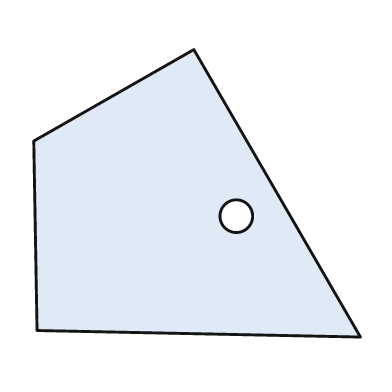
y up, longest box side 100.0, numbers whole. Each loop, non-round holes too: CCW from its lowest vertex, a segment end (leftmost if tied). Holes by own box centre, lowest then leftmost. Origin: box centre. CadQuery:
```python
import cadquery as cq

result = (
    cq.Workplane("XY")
    .moveTo(50.0, -44.0)
    .lineTo(-1.0, 44.0)
    .lineTo(-50.0, 16.0)
    .lineTo(-49.0, -42.0)
    .close()
    .moveTo(12.0, -7.0)
    .circle(5.0)
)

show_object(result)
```